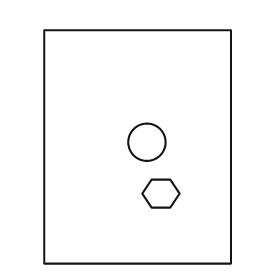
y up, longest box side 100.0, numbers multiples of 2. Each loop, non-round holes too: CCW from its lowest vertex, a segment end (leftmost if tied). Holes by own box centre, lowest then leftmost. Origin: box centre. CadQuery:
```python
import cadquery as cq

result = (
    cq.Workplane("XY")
    .moveTo(-40.0, -50.0)
    .lineTo(40.0, -50.0)
    .lineTo(40.0, 50.0)
    .lineTo(-40.0, 50.0)
    .close()
    .moveTo(6.0, -26.0)
    .lineTo(14.0, -26.0)
    .lineTo(18.0, -20.0)
    .lineTo(14.0, -14.0)
    .lineTo(6.0, -14.0)
    .lineTo(2.0, -20.0)
    .close()
    .moveTo(4.0, 2.0)
    .circle(8.0)
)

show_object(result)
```